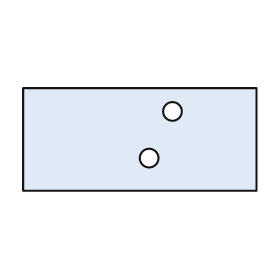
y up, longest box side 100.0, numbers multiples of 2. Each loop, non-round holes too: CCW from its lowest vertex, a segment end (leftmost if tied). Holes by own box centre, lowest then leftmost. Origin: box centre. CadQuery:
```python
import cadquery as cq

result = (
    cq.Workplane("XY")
    .moveTo(-50.0, -22.0)
    .lineTo(50.0, -22.0)
    .lineTo(50.0, 22.0)
    .lineTo(-50.0, 22.0)
    .close()
    .moveTo(4.0, -8.0)
    .circle(4.0)
    .moveTo(14.0, 12.0)
    .circle(4.0)
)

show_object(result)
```